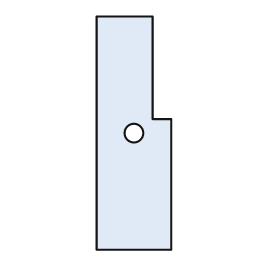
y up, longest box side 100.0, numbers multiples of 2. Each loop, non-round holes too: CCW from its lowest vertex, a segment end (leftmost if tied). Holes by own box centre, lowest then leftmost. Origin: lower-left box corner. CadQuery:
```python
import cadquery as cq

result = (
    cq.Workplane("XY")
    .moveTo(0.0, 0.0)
    .lineTo(32.0, 0.0)
    .lineTo(32.0, 56.0)
    .lineTo(24.0, 56.0)
    .lineTo(24.0, 100.0)
    .lineTo(0.0, 100.0)
    .close()
    .moveTo(16.0, 50.0)
    .circle(4.0)
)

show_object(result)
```